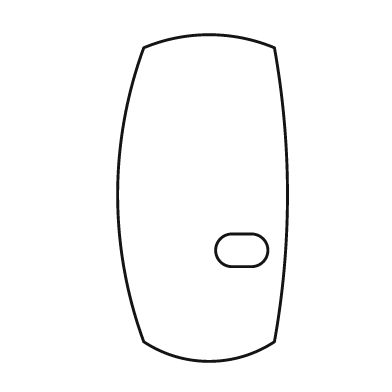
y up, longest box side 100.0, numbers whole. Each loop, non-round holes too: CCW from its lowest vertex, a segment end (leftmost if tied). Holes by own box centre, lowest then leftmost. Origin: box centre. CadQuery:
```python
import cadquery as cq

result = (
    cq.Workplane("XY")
    .moveTo(-18.0, -44.0)
    .threePointArc((2.0, -50.0), (22.0, -44.0))
    .threePointArc((26.0, 1.0), (22.0, 46.0))
    .threePointArc((2.0, 50.0), (-18.0, 46.0))
    .threePointArc((-26.0, 1.0), (-18.0, -44.0))
    .close()
    .moveTo(9.0, -21.0)
    .lineTo(15.0, -21.0)
    .threePointArc((20.0, -16.0), (15.0, -11.0))
    .lineTo(9.0, -11.0)
    .threePointArc((4.0, -16.0), (9.0, -21.0))
    .close()
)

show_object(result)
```